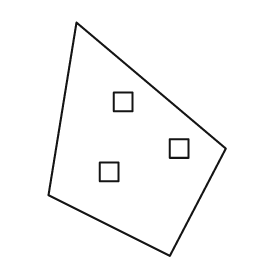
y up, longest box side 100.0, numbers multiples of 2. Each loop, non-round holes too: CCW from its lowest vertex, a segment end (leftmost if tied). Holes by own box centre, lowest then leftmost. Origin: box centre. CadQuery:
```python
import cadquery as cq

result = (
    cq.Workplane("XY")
    .moveTo(14.0, -50.0)
    .lineTo(38.0, -4.0)
    .lineTo(-26.0, 50.0)
    .lineTo(-38.0, -24.0)
    .close()
    .moveTo(-16.0, -18.0)
    .lineTo(-8.0, -18.0)
    .lineTo(-8.0, -10.0)
    .lineTo(-16.0, -10.0)
    .close()
    .moveTo(14.0, -8.0)
    .lineTo(22.0, -8.0)
    .lineTo(22.0, 0.0)
    .lineTo(14.0, 0.0)
    .close()
    .moveTo(-10.0, 12.0)
    .lineTo(-2.0, 12.0)
    .lineTo(-2.0, 20.0)
    .lineTo(-10.0, 20.0)
    .close()
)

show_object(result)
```